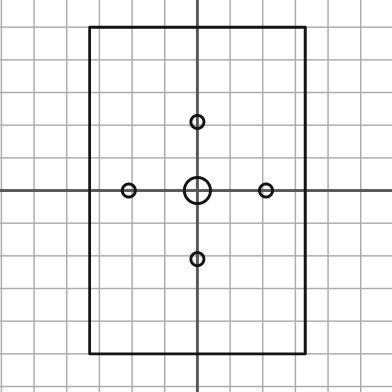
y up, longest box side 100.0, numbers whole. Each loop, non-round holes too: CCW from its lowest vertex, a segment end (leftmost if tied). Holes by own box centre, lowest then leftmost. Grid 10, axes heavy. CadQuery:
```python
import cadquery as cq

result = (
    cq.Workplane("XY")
    .moveTo(-33.0, -50.0)
    .lineTo(33.0, -50.0)
    .lineTo(33.0, 50.0)
    .lineTo(-33.0, 50.0)
    .close()
    .moveTo(0.0, -21.0)
    .circle(2.0)
    .moveTo(-21.0, 0.0)
    .circle(2.0)
    .moveTo(0.0, 0.0)
    .circle(4.0)
    .moveTo(21.0, 0.0)
    .circle(2.0)
    .moveTo(0.0, 21.0)
    .circle(2.0)
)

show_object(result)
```